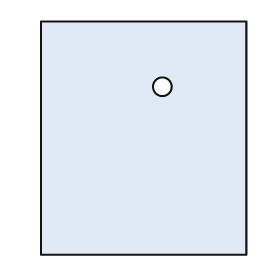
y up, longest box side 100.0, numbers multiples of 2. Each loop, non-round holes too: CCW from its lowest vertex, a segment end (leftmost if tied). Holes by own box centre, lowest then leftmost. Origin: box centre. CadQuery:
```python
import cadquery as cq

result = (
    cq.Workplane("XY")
    .moveTo(-44.0, -50.0)
    .lineTo(44.0, -50.0)
    .lineTo(44.0, 50.0)
    .lineTo(-44.0, 50.0)
    .close()
    .moveTo(8.0, 22.0)
    .circle(4.0)
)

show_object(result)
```